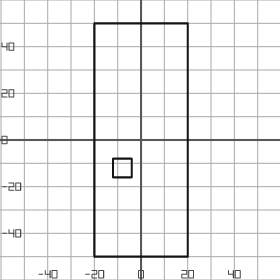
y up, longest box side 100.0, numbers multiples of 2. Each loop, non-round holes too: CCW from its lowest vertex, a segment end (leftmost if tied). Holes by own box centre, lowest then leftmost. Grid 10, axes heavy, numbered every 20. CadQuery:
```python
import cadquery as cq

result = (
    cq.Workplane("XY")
    .moveTo(-20.0, -50.0)
    .lineTo(20.0, -50.0)
    .lineTo(20.0, 50.0)
    .lineTo(-20.0, 50.0)
    .close()
    .moveTo(-12.0, -16.0)
    .lineTo(-4.0, -16.0)
    .lineTo(-4.0, -8.0)
    .lineTo(-12.0, -8.0)
    .close()
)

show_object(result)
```